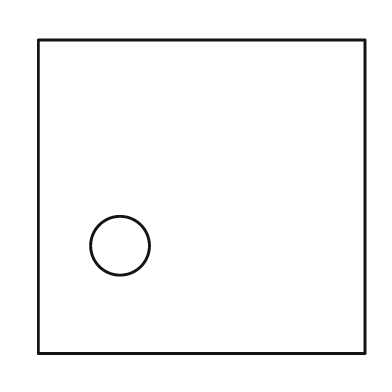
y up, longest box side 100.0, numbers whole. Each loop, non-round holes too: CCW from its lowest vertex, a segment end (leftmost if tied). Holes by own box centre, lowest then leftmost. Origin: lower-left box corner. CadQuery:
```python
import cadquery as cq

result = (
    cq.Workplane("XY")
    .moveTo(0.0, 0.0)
    .lineTo(100.0, 0.0)
    .lineTo(100.0, 96.0)
    .lineTo(0.0, 96.0)
    .close()
    .moveTo(25.0, 33.0)
    .circle(9.0)
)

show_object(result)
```